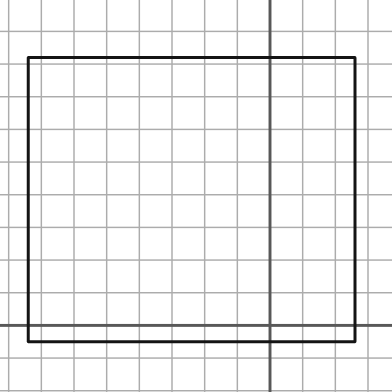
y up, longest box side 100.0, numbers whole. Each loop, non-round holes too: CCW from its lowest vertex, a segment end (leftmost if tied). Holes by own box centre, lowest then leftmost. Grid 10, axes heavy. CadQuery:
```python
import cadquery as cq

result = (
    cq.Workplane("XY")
    .moveTo(-74.0, -5.0)
    .lineTo(26.0, -5.0)
    .lineTo(26.0, 82.0)
    .lineTo(-74.0, 82.0)
    .close()
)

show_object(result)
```